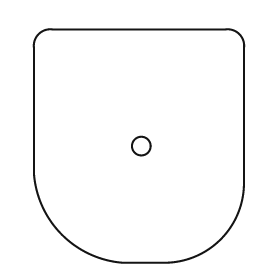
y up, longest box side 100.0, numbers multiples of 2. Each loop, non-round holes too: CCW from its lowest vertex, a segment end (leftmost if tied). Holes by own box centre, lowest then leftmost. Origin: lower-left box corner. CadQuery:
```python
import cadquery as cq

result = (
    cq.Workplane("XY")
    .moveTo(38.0, 0.0)
    .lineTo(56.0, 0.0)
    .threePointArc((80.0, 10.0), (90.0, 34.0))
    .lineTo(90.0, 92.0)
    .threePointArc((88.0, 98.0), (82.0, 100.0))
    .lineTo(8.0, 100.0)
    .threePointArc((2.0, 98.0), (0.0, 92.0))
    .lineTo(0.0, 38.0)
    .threePointArc((12.0, 12.0), (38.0, 0.0))
    .close()
    .moveTo(46.0, 50.0)
    .circle(4.0)
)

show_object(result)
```